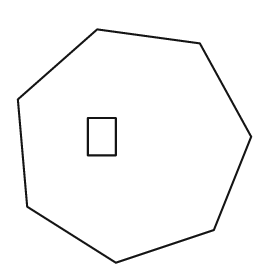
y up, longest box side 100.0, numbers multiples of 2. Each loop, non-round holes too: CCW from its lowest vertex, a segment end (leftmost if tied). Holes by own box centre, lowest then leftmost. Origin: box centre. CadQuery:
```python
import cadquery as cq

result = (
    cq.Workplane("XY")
    .moveTo(-8.0, -50.0)
    .lineTo(34.0, -36.0)
    .lineTo(50.0, 4.0)
    .lineTo(28.0, 44.0)
    .lineTo(-16.0, 50.0)
    .lineTo(-50.0, 20.0)
    .lineTo(-46.0, -26.0)
    .close()
    .moveTo(-20.0, -4.0)
    .lineTo(-8.0, -4.0)
    .lineTo(-8.0, 12.0)
    .lineTo(-20.0, 12.0)
    .close()
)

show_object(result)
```